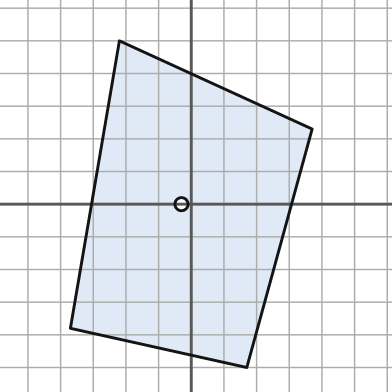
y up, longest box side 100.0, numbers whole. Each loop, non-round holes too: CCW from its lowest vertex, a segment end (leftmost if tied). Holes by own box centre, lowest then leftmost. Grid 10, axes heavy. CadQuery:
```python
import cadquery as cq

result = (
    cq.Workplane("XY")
    .moveTo(17.0, -50.0)
    .lineTo(37.0, 23.0)
    .lineTo(-22.0, 50.0)
    .lineTo(-37.0, -38.0)
    .close()
    .moveTo(-3.0, 0.0)
    .circle(2.0)
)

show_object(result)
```